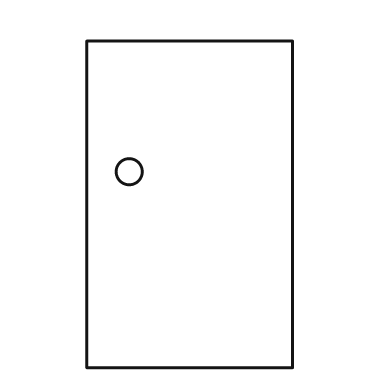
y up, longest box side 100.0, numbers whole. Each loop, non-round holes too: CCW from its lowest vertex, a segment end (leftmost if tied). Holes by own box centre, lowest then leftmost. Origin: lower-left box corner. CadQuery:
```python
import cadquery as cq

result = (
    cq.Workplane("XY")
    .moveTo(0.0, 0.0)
    .lineTo(63.0, 0.0)
    .lineTo(63.0, 100.0)
    .lineTo(0.0, 100.0)
    .close()
    .moveTo(13.0, 60.0)
    .circle(4.0)
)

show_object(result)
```